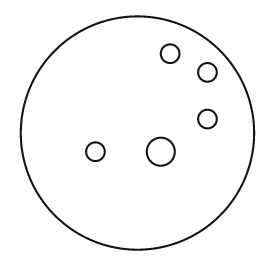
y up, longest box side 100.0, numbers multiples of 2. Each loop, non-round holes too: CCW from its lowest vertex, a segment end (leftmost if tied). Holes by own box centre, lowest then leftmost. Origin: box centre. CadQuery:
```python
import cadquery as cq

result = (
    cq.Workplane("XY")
    .moveTo(0.0, 0.0)
    .circle(50.0)
    .moveTo(-18.0, -8.0)
    .circle(4.0)
    .moveTo(10.0, -8.0)
    .circle(6.0)
    .moveTo(30.0, 6.0)
    .circle(4.0)
    .moveTo(30.0, 26.0)
    .circle(4.0)
    .moveTo(14.0, 34.0)
    .circle(4.0)
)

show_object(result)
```